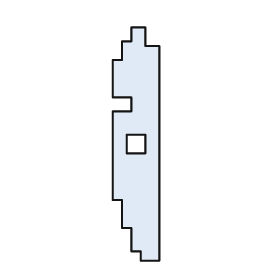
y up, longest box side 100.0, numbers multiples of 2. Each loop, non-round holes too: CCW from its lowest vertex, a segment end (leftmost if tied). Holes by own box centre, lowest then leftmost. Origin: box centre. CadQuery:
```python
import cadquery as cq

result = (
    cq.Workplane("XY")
    .moveTo(2.0, -50.0)
    .lineTo(10.0, -50.0)
    .lineTo(10.0, 42.0)
    .lineTo(4.0, 42.0)
    .lineTo(4.0, 50.0)
    .lineTo(-2.0, 50.0)
    .lineTo(-2.0, 44.0)
    .lineTo(-6.0, 44.0)
    .lineTo(-6.0, 36.0)
    .lineTo(-10.0, 36.0)
    .lineTo(-10.0, 20.0)
    .lineTo(-2.0, 20.0)
    .lineTo(-2.0, 14.0)
    .lineTo(-10.0, 14.0)
    .lineTo(-10.0, -24.0)
    .lineTo(-6.0, -24.0)
    .lineTo(-6.0, -36.0)
    .lineTo(-2.0, -36.0)
    .lineTo(-2.0, -46.0)
    .lineTo(2.0, -46.0)
    .close()
    .moveTo(-4.0, -4.0)
    .lineTo(4.0, -4.0)
    .lineTo(4.0, 4.0)
    .lineTo(-4.0, 4.0)
    .close()
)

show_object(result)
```